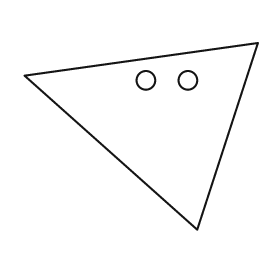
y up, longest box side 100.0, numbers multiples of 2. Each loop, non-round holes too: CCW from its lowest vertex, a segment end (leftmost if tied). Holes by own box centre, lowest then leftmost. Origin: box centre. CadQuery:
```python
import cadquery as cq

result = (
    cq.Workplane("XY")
    .moveTo(24.0, -40.0)
    .lineTo(50.0, 40.0)
    .lineTo(-50.0, 26.0)
    .close()
    .moveTo(2.0, 24.0)
    .circle(4.0)
    .moveTo(20.0, 24.0)
    .circle(4.0)
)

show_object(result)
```